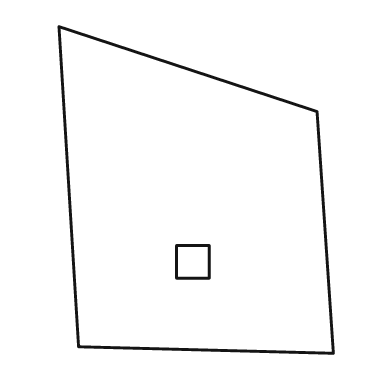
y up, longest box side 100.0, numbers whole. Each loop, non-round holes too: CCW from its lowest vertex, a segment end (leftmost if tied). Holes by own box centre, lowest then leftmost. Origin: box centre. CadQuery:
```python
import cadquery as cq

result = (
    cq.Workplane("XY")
    .moveTo(42.0, -50.0)
    .lineTo(37.0, 24.0)
    .lineTo(-42.0, 50.0)
    .lineTo(-36.0, -48.0)
    .close()
    .moveTo(-6.0, -27.0)
    .lineTo(4.0, -27.0)
    .lineTo(4.0, -17.0)
    .lineTo(-6.0, -17.0)
    .close()
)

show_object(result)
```